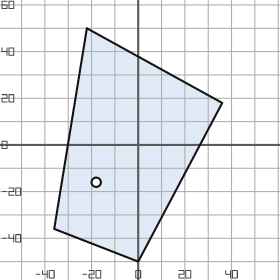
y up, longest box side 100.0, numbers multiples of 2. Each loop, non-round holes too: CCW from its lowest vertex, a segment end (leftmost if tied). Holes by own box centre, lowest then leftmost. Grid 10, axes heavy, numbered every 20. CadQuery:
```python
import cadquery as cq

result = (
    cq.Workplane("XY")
    .moveTo(0.0, -50.0)
    .lineTo(36.0, 18.0)
    .lineTo(-22.0, 50.0)
    .lineTo(-36.0, -36.0)
    .close()
    .moveTo(-18.0, -16.0)
    .circle(2.0)
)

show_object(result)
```